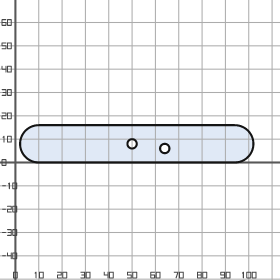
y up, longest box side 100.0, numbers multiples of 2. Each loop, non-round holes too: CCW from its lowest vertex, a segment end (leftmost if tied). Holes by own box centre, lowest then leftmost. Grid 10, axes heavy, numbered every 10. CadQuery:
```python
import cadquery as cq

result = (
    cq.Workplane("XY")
    .moveTo(10.0, 0.0)
    .lineTo(94.0, 0.0)
    .threePointArc((102.0, 8.0), (94.0, 16.0))
    .lineTo(10.0, 16.0)
    .threePointArc((2.0, 8.0), (10.0, 0.0))
    .close()
    .moveTo(64.0, 6.0)
    .circle(2.0)
    .moveTo(50.0, 8.0)
    .circle(2.0)
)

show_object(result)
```